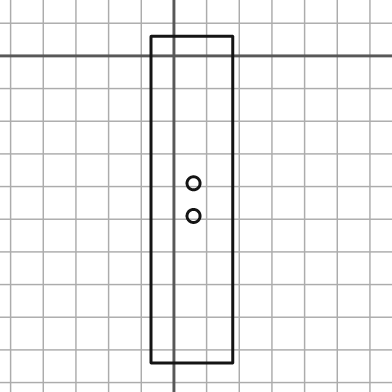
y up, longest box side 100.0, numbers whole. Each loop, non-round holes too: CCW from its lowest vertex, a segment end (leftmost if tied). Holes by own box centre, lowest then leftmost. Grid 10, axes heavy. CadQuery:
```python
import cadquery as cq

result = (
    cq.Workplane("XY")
    .moveTo(-7.0, -94.0)
    .lineTo(18.0, -94.0)
    .lineTo(18.0, 6.0)
    .lineTo(-7.0, 6.0)
    .close()
    .moveTo(6.0, -49.0)
    .circle(2.0)
    .moveTo(6.0, -39.0)
    .circle(2.0)
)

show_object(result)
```